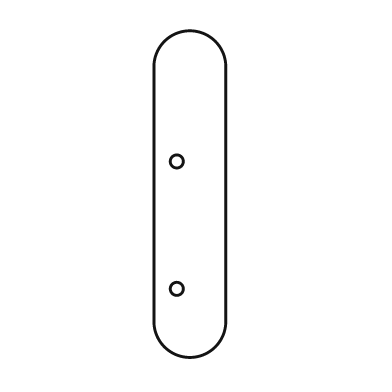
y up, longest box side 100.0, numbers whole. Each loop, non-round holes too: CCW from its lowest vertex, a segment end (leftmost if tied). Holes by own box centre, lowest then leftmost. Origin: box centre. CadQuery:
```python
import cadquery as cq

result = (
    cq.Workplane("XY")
    .moveTo(-11.0, -39.0)
    .threePointArc((0.0, -50.0), (11.0, -39.0))
    .lineTo(11.0, 39.0)
    .threePointArc((0.0, 50.0), (-11.0, 39.0))
    .close()
    .moveTo(-4.0, -29.0)
    .circle(2.0)
    .moveTo(-4.0, 10.0)
    .circle(2.0)
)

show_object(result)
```